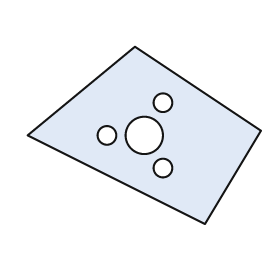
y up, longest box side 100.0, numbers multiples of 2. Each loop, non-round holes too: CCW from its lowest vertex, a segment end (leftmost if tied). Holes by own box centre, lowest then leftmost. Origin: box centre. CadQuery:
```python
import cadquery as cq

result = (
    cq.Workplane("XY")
    .moveTo(26.0, -38.0)
    .lineTo(50.0, 2.0)
    .lineTo(-4.0, 38.0)
    .lineTo(-50.0, 0.0)
    .close()
    .moveTo(8.0, -14.0)
    .circle(4.0)
    .moveTo(-16.0, 0.0)
    .circle(4.0)
    .moveTo(0.0, 0.0)
    .circle(8.0)
    .moveTo(8.0, 14.0)
    .circle(4.0)
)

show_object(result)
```